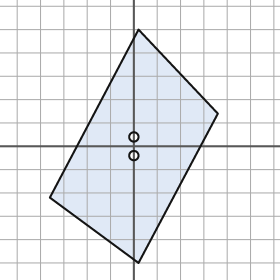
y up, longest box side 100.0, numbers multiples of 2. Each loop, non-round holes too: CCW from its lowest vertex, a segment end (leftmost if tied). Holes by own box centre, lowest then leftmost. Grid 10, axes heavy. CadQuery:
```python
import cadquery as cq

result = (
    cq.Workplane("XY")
    .moveTo(2.0, -50.0)
    .lineTo(36.0, 14.0)
    .lineTo(2.0, 50.0)
    .lineTo(-36.0, -22.0)
    .close()
    .moveTo(0.0, -4.0)
    .circle(2.0)
    .moveTo(0.0, 4.0)
    .circle(2.0)
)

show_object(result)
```